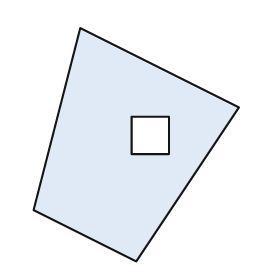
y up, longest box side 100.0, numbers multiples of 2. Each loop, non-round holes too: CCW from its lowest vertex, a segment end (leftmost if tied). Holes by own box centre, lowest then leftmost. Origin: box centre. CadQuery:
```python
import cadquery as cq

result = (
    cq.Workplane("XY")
    .moveTo(0.0, -50.0)
    .lineTo(44.0, 16.0)
    .lineTo(-24.0, 50.0)
    .lineTo(-44.0, -28.0)
    .close()
    .moveTo(-2.0, -4.0)
    .lineTo(14.0, -4.0)
    .lineTo(14.0, 12.0)
    .lineTo(-2.0, 12.0)
    .close()
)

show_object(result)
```